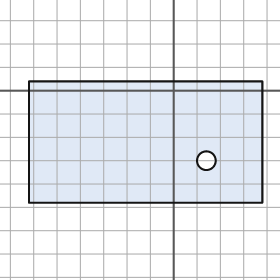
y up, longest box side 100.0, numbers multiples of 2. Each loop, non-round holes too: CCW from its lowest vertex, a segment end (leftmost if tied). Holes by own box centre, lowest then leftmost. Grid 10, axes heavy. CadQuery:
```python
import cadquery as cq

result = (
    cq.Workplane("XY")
    .moveTo(-62.0, -48.0)
    .lineTo(38.0, -48.0)
    .lineTo(38.0, 4.0)
    .lineTo(-62.0, 4.0)
    .close()
    .moveTo(14.0, -30.0)
    .circle(4.0)
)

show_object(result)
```